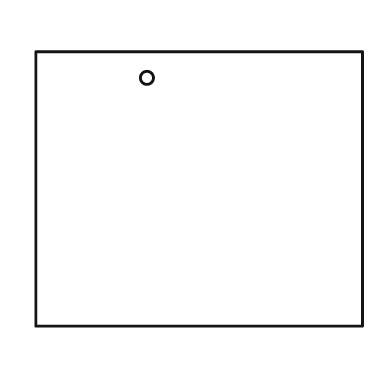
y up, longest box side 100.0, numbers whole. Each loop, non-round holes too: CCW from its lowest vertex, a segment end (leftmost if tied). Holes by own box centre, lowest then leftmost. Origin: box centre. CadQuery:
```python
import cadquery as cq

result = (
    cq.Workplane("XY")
    .moveTo(-50.0, -42.0)
    .lineTo(50.0, -42.0)
    .lineTo(50.0, 42.0)
    .lineTo(-50.0, 42.0)
    .close()
    .moveTo(-16.0, 34.0)
    .circle(2.0)
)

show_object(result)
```